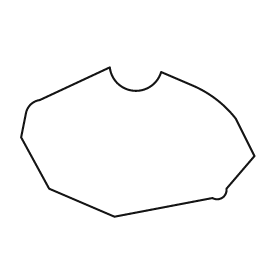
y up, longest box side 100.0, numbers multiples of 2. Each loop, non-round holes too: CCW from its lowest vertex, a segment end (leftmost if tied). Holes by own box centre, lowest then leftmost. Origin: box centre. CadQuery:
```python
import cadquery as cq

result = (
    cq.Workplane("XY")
    .moveTo(-10.0, -32.0)
    .lineTo(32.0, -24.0)
    .threePointArc((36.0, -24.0), (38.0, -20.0))
    .lineTo(50.0, -6.0)
    .lineTo(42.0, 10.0)
    .threePointArc((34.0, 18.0), (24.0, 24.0))
    .lineTo(10.0, 30.0)
    .threePointArc((-2.0, 22.0), (-12.0, 32.0))
    .lineTo(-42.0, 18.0)
    .threePointArc((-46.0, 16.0), (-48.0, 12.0))
    .lineTo(-50.0, 2.0)
    .lineTo(-38.0, -20.0)
    .close()
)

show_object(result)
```